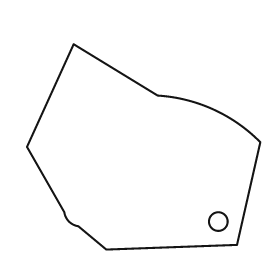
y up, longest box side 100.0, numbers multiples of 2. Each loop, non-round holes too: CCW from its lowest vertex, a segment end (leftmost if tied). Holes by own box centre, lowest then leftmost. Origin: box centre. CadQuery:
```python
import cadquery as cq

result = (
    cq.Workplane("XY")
    .moveTo(-16.0, -44.0)
    .lineTo(40.0, -42.0)
    .lineTo(50.0, 2.0)
    .threePointArc((30.0, 16.0), (6.0, 22.0))
    .lineTo(-30.0, 44.0)
    .lineTo(-50.0, 0.0)
    .lineTo(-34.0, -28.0)
    .threePointArc((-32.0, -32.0), (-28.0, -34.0))
    .close()
    .moveTo(32.0, -32.0)
    .circle(4.0)
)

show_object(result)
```